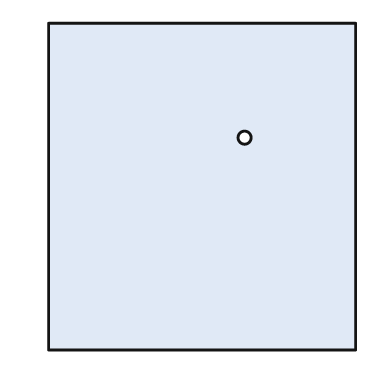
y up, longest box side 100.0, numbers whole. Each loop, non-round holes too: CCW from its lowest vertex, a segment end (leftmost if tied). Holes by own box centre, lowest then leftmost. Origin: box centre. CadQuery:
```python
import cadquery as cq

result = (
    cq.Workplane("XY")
    .moveTo(-47.0, -50.0)
    .lineTo(47.0, -50.0)
    .lineTo(47.0, 50.0)
    .lineTo(-47.0, 50.0)
    .close()
    .moveTo(13.0, 15.0)
    .circle(2.0)
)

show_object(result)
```